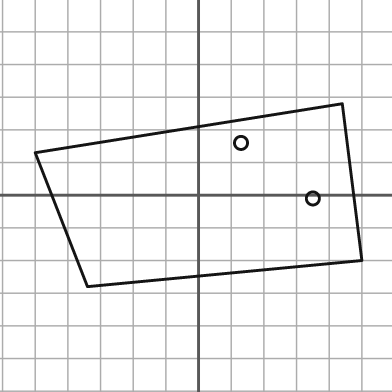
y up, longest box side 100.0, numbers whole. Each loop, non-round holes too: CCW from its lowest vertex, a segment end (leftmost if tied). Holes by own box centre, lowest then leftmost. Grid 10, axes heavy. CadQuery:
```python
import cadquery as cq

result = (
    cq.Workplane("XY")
    .moveTo(-34.0, -28.0)
    .lineTo(50.0, -20.0)
    .lineTo(44.0, 28.0)
    .lineTo(-50.0, 13.0)
    .close()
    .moveTo(35.0, -1.0)
    .circle(2.0)
    .moveTo(13.0, 16.0)
    .circle(2.0)
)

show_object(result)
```